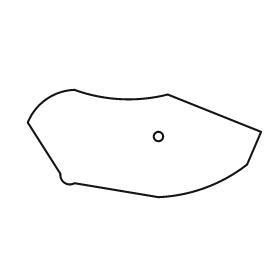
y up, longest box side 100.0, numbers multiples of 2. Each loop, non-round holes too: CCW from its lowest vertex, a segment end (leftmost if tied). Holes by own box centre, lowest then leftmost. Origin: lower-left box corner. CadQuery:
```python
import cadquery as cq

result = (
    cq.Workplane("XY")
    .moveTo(56.0, 0.0)
    .threePointArc((76.0, 4.0), (94.0, 14.0))
    .lineTo(100.0, 28.0)
    .lineTo(60.0, 44.0)
    .threePointArc((40.0, 42.0), (20.0, 46.0))
    .threePointArc((8.0, 42.0), (0.0, 32.0))
    .lineTo(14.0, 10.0)
    .threePointArc((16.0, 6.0), (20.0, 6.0))
    .close()
    .moveTo(56.0, 26.0)
    .circle(2.0)
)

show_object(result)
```